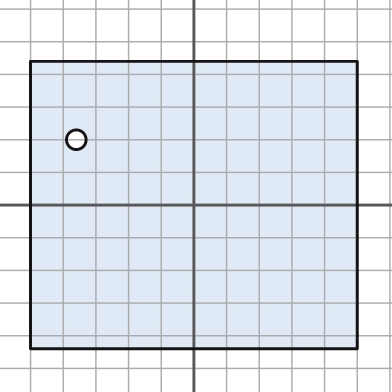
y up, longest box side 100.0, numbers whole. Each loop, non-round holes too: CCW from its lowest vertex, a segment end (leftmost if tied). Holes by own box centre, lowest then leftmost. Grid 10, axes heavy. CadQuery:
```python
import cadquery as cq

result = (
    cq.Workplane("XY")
    .moveTo(-50.0, -44.0)
    .lineTo(50.0, -44.0)
    .lineTo(50.0, 44.0)
    .lineTo(-50.0, 44.0)
    .close()
    .moveTo(-36.0, 20.0)
    .circle(3.0)
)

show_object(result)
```